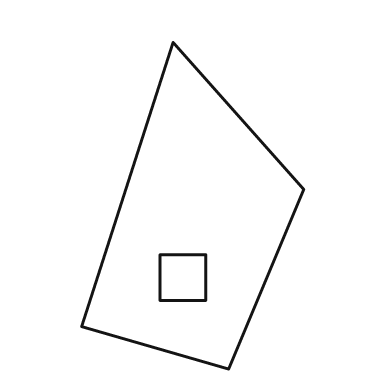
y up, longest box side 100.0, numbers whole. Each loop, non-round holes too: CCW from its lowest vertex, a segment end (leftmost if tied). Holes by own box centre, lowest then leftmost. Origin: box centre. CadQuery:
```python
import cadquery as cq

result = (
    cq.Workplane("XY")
    .moveTo(11.0, -50.0)
    .lineTo(34.0, 5.0)
    .lineTo(-6.0, 50.0)
    .lineTo(-34.0, -37.0)
    .close()
    .moveTo(-10.0, -29.0)
    .lineTo(4.0, -29.0)
    .lineTo(4.0, -15.0)
    .lineTo(-10.0, -15.0)
    .close()
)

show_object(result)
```